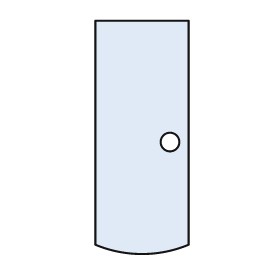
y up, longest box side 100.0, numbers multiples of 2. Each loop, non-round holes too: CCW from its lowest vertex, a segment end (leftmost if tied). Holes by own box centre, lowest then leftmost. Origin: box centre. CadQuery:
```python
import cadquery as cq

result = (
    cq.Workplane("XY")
    .moveTo(-20.0, -46.0)
    .threePointArc((0.0, -50.0), (20.0, -46.0))
    .lineTo(20.0, 50.0)
    .lineTo(-20.0, 50.0)
    .close()
    .moveTo(12.0, -2.0)
    .circle(4.0)
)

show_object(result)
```